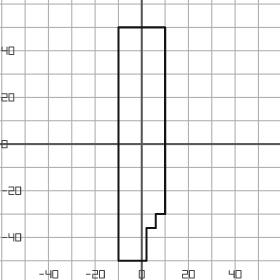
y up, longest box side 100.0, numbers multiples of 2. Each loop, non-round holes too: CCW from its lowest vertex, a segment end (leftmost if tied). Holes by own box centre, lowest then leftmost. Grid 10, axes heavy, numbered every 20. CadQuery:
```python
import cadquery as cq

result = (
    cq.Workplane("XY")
    .moveTo(-10.0, -50.0)
    .lineTo(2.0, -50.0)
    .lineTo(2.0, -36.0)
    .lineTo(6.0, -36.0)
    .lineTo(6.0, -30.0)
    .lineTo(10.0, -30.0)
    .lineTo(10.0, 50.0)
    .lineTo(-10.0, 50.0)
    .close()
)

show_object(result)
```